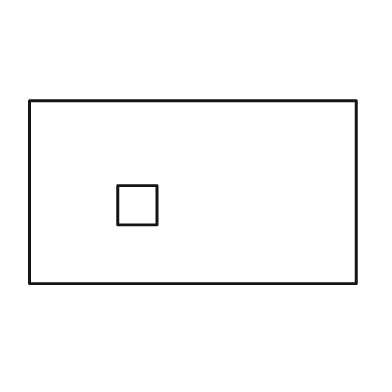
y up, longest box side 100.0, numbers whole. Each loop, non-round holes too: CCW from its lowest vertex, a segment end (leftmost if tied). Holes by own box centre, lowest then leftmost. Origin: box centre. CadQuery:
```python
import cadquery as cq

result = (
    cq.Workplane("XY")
    .moveTo(-50.0, -28.0)
    .lineTo(50.0, -28.0)
    .lineTo(50.0, 28.0)
    .lineTo(-50.0, 28.0)
    .close()
    .moveTo(-23.0, -10.0)
    .lineTo(-11.0, -10.0)
    .lineTo(-11.0, 2.0)
    .lineTo(-23.0, 2.0)
    .close()
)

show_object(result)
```